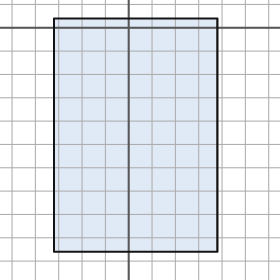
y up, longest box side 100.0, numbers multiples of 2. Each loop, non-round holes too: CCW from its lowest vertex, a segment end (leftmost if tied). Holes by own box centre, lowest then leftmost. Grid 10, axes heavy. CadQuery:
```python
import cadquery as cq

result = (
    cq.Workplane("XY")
    .moveTo(-32.0, -96.0)
    .lineTo(38.0, -96.0)
    .lineTo(38.0, 4.0)
    .lineTo(-32.0, 4.0)
    .close()
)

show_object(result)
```